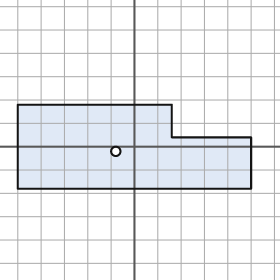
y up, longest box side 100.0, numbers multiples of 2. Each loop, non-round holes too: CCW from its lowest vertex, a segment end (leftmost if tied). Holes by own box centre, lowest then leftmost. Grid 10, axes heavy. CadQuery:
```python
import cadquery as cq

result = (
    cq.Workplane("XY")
    .moveTo(-50.0, -18.0)
    .lineTo(50.0, -18.0)
    .lineTo(50.0, 4.0)
    .lineTo(16.0, 4.0)
    .lineTo(16.0, 18.0)
    .lineTo(-50.0, 18.0)
    .close()
    .moveTo(-8.0, -2.0)
    .circle(2.0)
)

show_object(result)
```